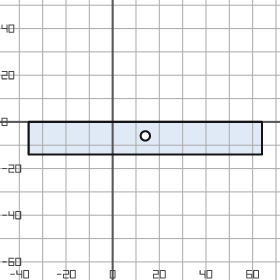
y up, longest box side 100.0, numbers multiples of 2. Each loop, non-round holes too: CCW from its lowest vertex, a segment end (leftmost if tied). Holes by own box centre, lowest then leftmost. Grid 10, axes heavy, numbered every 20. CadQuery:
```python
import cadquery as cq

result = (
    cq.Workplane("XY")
    .moveTo(-36.0, -14.0)
    .lineTo(64.0, -14.0)
    .lineTo(64.0, 0.0)
    .lineTo(-36.0, 0.0)
    .close()
    .moveTo(14.0, -6.0)
    .circle(2.0)
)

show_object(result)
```